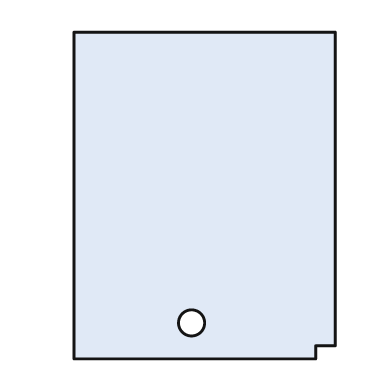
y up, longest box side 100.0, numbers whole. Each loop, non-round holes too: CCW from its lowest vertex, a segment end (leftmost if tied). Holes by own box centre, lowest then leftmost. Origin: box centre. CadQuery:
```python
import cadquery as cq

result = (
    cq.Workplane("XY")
    .moveTo(-40.0, -50.0)
    .lineTo(34.0, -50.0)
    .lineTo(34.0, -46.0)
    .lineTo(40.0, -46.0)
    .lineTo(40.0, 50.0)
    .lineTo(-40.0, 50.0)
    .close()
    .moveTo(-4.0, -39.0)
    .circle(4.0)
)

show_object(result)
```